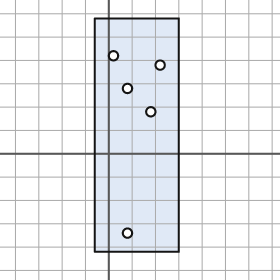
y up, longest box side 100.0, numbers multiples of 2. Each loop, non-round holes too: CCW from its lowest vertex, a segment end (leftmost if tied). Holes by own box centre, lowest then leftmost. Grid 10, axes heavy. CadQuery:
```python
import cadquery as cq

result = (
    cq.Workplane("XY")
    .moveTo(-6.0, -42.0)
    .lineTo(30.0, -42.0)
    .lineTo(30.0, 58.0)
    .lineTo(-6.0, 58.0)
    .close()
    .moveTo(8.0, -34.0)
    .circle(2.0)
    .moveTo(18.0, 18.0)
    .circle(2.0)
    .moveTo(8.0, 28.0)
    .circle(2.0)
    .moveTo(22.0, 38.0)
    .circle(2.0)
    .moveTo(2.0, 42.0)
    .circle(2.0)
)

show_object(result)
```